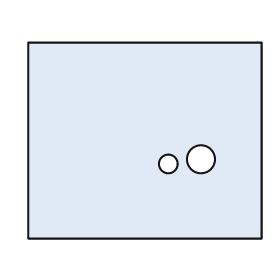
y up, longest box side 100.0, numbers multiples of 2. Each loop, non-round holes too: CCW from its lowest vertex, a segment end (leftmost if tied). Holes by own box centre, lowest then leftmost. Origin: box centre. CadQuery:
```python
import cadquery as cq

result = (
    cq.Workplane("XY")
    .moveTo(-50.0, -42.0)
    .lineTo(50.0, -42.0)
    .lineTo(50.0, 42.0)
    .lineTo(-50.0, 42.0)
    .close()
    .moveTo(10.0, -10.0)
    .circle(4.0)
    .moveTo(24.0, -8.0)
    .circle(6.0)
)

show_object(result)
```